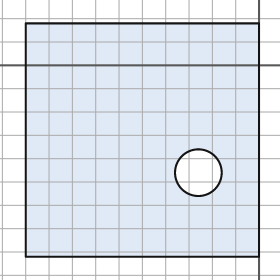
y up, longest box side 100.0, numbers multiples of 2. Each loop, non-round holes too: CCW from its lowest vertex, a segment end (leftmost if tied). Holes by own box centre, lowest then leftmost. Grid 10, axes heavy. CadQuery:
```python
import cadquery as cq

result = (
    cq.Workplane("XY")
    .moveTo(-100.0, -82.0)
    .lineTo(0.0, -82.0)
    .lineTo(0.0, 18.0)
    .lineTo(-100.0, 18.0)
    .close()
    .moveTo(-26.0, -46.0)
    .circle(10.0)
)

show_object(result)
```